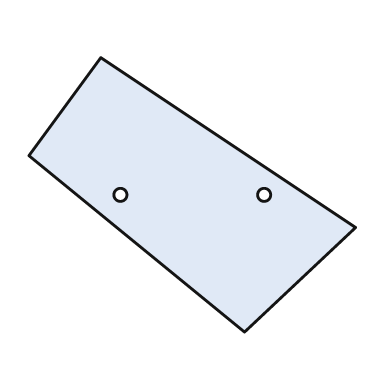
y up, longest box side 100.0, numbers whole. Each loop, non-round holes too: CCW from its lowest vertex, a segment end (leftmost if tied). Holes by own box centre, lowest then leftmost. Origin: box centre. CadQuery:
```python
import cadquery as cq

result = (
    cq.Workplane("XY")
    .moveTo(16.0, -42.0)
    .lineTo(50.0, -10.0)
    .lineTo(-28.0, 42.0)
    .lineTo(-50.0, 12.0)
    .close()
    .moveTo(-22.0, 0.0)
    .circle(2.0)
    .moveTo(22.0, 0.0)
    .circle(2.0)
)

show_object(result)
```